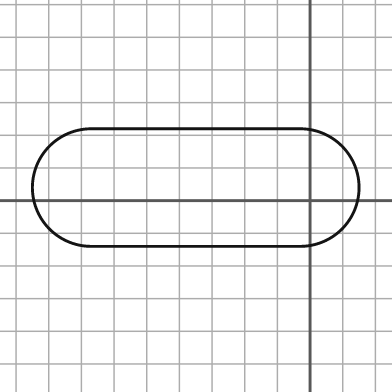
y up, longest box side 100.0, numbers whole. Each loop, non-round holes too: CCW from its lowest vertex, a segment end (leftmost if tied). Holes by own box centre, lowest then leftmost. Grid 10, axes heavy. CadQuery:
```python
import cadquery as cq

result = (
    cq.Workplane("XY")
    .moveTo(-67.0, -14.0)
    .lineTo(-3.0, -14.0)
    .threePointArc((15.0, 4.0), (-3.0, 22.0))
    .lineTo(-67.0, 22.0)
    .threePointArc((-85.0, 4.0), (-67.0, -14.0))
    .close()
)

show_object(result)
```